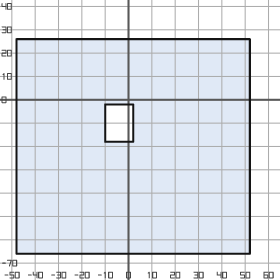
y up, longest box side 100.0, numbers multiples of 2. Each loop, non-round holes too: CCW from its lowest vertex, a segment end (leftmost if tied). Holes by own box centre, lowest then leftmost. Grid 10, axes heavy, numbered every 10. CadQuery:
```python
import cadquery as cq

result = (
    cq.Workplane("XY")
    .moveTo(-48.0, -66.0)
    .lineTo(52.0, -66.0)
    .lineTo(52.0, 26.0)
    .lineTo(-48.0, 26.0)
    .close()
    .moveTo(-10.0, -18.0)
    .lineTo(2.0, -18.0)
    .lineTo(2.0, -2.0)
    .lineTo(-10.0, -2.0)
    .close()
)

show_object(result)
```